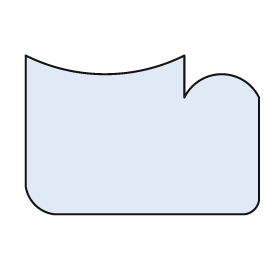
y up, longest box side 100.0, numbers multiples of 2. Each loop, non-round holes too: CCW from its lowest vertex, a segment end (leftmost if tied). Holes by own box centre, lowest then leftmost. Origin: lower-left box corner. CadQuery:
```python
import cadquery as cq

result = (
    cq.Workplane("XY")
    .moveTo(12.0, 0.0)
    .lineTo(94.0, 0.0)
    .threePointArc((98.0, 2.0), (100.0, 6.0))
    .lineTo(100.0, 50.0)
    .threePointArc((84.0, 60.0), (68.0, 50.0))
    .lineTo(68.0, 68.0)
    .threePointArc((34.0, 60.0), (0.0, 68.0))
    .lineTo(0.0, 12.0)
    .threePointArc((4.0, 4.0), (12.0, 0.0))
    .close()
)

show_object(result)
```